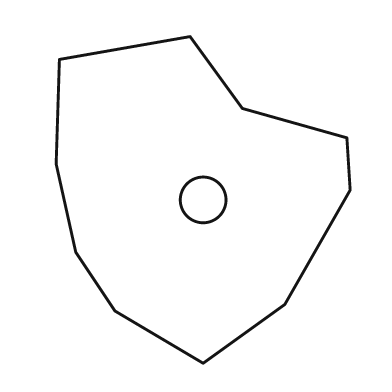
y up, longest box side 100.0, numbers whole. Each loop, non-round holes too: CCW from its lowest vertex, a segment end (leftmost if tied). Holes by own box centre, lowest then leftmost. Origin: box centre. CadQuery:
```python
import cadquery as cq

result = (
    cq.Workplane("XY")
    .moveTo(0.0, -50.0)
    .lineTo(25.0, -32.0)
    .lineTo(45.0, 3.0)
    .lineTo(44.0, 19.0)
    .lineTo(12.0, 28.0)
    .lineTo(-4.0, 50.0)
    .lineTo(-44.0, 43.0)
    .lineTo(-45.0, 11.0)
    .lineTo(-39.0, -16.0)
    .lineTo(-27.0, -34.0)
    .close()
    .moveTo(0.0, 0.0)
    .circle(7.0)
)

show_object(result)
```